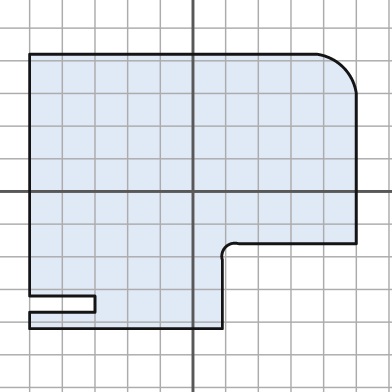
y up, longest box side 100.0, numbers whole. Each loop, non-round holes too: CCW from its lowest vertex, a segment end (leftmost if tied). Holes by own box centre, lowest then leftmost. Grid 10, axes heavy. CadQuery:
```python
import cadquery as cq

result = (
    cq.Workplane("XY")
    .moveTo(-50.0, -42.0)
    .lineTo(9.0, -42.0)
    .lineTo(9.0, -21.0)
    .threePointArc((10.0, -17.0), (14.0, -16.0))
    .lineTo(50.0, -16.0)
    .lineTo(50.0, 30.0)
    .threePointArc((46.0, 38.0), (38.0, 42.0))
    .lineTo(-50.0, 42.0)
    .lineTo(-50.0, -32.0)
    .lineTo(-30.0, -32.0)
    .lineTo(-30.0, -37.0)
    .lineTo(-50.0, -37.0)
    .close()
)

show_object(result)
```